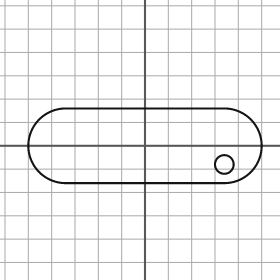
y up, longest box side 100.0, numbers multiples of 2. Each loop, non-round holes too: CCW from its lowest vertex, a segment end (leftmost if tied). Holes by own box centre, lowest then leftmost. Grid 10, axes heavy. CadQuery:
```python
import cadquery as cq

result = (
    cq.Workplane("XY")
    .moveTo(-34.0, -16.0)
    .lineTo(34.0, -16.0)
    .threePointArc((50.0, 0.0), (34.0, 16.0))
    .lineTo(-34.0, 16.0)
    .threePointArc((-50.0, 0.0), (-34.0, -16.0))
    .close()
    .moveTo(34.0, -8.0)
    .circle(4.0)
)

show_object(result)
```